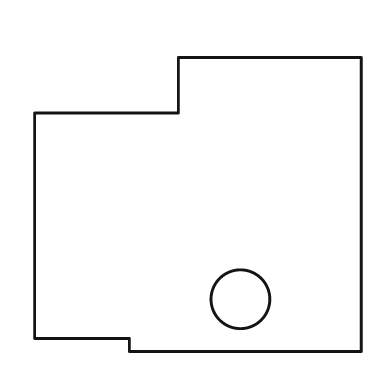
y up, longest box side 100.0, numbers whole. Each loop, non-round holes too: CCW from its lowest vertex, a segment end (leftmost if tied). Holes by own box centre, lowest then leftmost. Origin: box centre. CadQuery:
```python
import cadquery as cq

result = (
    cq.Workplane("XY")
    .moveTo(-21.0, -45.0)
    .lineTo(50.0, -45.0)
    .lineTo(50.0, 45.0)
    .lineTo(-6.0, 45.0)
    .lineTo(-6.0, 28.0)
    .lineTo(-50.0, 28.0)
    .lineTo(-50.0, -41.0)
    .lineTo(-21.0, -41.0)
    .close()
    .moveTo(13.0, -29.0)
    .circle(9.0)
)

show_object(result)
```